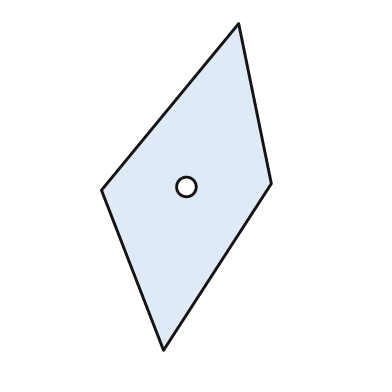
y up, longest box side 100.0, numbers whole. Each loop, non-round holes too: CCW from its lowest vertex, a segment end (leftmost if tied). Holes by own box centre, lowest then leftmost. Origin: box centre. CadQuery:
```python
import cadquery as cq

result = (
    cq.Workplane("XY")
    .moveTo(-7.0, -50.0)
    .lineTo(26.0, 1.0)
    .lineTo(16.0, 50.0)
    .lineTo(-26.0, -1.0)
    .close()
    .moveTo(0.0, 0.0)
    .circle(3.0)
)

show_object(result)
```